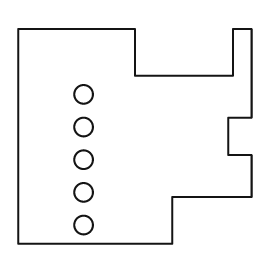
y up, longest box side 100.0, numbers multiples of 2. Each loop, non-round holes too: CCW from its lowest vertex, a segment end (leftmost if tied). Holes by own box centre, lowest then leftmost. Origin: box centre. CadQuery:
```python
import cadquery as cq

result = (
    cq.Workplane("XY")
    .moveTo(-50.0, -46.0)
    .lineTo(16.0, -46.0)
    .lineTo(16.0, -26.0)
    .lineTo(50.0, -26.0)
    .lineTo(50.0, -8.0)
    .lineTo(40.0, -8.0)
    .lineTo(40.0, 8.0)
    .lineTo(50.0, 8.0)
    .lineTo(50.0, 46.0)
    .lineTo(42.0, 46.0)
    .lineTo(42.0, 26.0)
    .lineTo(0.0, 26.0)
    .lineTo(0.0, 46.0)
    .lineTo(-50.0, 46.0)
    .close()
    .moveTo(-22.0, -38.0)
    .circle(4.0)
    .moveTo(-22.0, -24.0)
    .circle(4.0)
    .moveTo(-22.0, -10.0)
    .circle(4.0)
    .moveTo(-22.0, 4.0)
    .circle(4.0)
    .moveTo(-22.0, 18.0)
    .circle(4.0)
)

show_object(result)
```